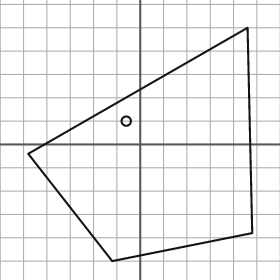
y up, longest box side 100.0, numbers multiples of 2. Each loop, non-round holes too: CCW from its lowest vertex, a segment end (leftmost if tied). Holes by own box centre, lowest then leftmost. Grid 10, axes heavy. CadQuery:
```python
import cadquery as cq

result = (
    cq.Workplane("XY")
    .moveTo(-12.0, -50.0)
    .lineTo(48.0, -38.0)
    .lineTo(46.0, 50.0)
    .lineTo(-48.0, -4.0)
    .close()
    .moveTo(-6.0, 10.0)
    .circle(2.0)
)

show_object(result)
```